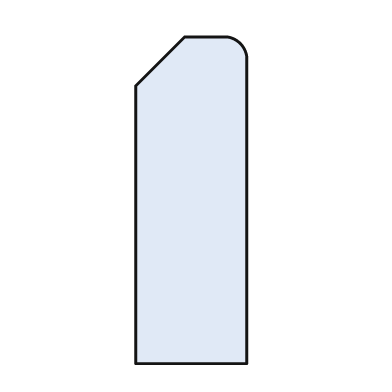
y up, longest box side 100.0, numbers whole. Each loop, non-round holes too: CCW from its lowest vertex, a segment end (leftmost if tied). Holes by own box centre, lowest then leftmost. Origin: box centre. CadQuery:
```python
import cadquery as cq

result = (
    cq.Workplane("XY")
    .moveTo(-17.0, -50.0)
    .lineTo(17.0, -50.0)
    .lineTo(17.0, 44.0)
    .threePointArc((15.0, 48.0), (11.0, 50.0))
    .lineTo(-2.0, 50.0)
    .lineTo(-17.0, 35.0)
    .close()
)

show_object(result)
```